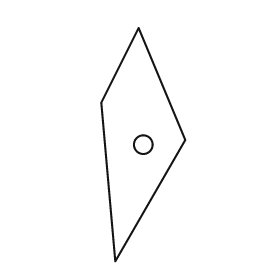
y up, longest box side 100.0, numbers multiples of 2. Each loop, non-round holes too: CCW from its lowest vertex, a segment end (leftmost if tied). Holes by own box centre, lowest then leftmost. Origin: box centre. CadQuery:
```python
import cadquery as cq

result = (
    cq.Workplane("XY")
    .moveTo(-12.0, -50.0)
    .lineTo(18.0, 2.0)
    .lineTo(-2.0, 50.0)
    .lineTo(-18.0, 18.0)
    .close()
    .moveTo(0.0, 0.0)
    .circle(4.0)
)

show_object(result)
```